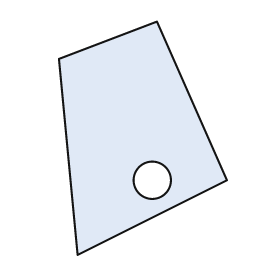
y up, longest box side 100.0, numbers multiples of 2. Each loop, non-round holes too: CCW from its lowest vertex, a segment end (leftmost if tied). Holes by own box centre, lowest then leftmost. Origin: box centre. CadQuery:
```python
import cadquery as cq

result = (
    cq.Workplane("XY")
    .moveTo(-28.0, -50.0)
    .lineTo(36.0, -18.0)
    .lineTo(6.0, 50.0)
    .lineTo(-36.0, 34.0)
    .close()
    .moveTo(4.0, -18.0)
    .circle(8.0)
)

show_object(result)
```